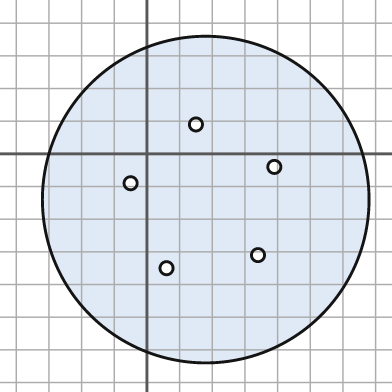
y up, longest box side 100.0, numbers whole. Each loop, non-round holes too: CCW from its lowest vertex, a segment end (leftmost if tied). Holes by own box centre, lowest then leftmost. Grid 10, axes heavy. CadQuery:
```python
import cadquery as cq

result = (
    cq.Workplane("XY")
    .moveTo(18.0, -14.0)
    .circle(50.0)
    .moveTo(6.0, -35.0)
    .circle(2.0)
    .moveTo(34.0, -31.0)
    .circle(2.0)
    .moveTo(-5.0, -9.0)
    .circle(2.0)
    .moveTo(39.0, -4.0)
    .circle(2.0)
    .moveTo(15.0, 9.0)
    .circle(2.0)
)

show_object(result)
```